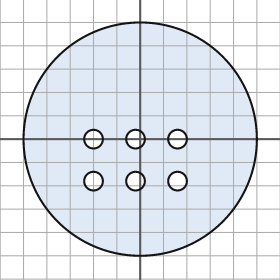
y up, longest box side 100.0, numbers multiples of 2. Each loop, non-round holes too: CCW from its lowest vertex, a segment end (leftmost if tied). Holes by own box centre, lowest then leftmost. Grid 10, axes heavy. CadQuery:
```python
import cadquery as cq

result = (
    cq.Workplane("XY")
    .moveTo(0.0, 0.0)
    .circle(50.0)
    .moveTo(-20.0, -18.0)
    .circle(4.0)
    .moveTo(-2.0, -18.0)
    .circle(4.0)
    .moveTo(16.0, -18.0)
    .circle(4.0)
    .moveTo(-20.0, 0.0)
    .circle(4.0)
    .moveTo(-2.0, 0.0)
    .circle(4.0)
    .moveTo(16.0, 0.0)
    .circle(4.0)
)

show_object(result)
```